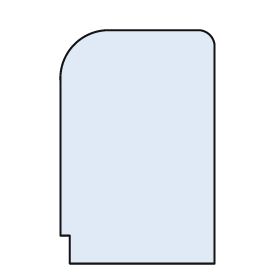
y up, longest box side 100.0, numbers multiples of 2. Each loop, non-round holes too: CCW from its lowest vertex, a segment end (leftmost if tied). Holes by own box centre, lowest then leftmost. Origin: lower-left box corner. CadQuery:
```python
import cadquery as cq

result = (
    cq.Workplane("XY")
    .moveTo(4.0, 0.0)
    .lineTo(66.0, 0.0)
    .lineTo(66.0, 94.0)
    .threePointArc((64.0, 98.0), (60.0, 100.0))
    .lineTo(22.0, 100.0)
    .threePointArc((6.0, 94.0), (0.0, 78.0))
    .lineTo(0.0, 12.0)
    .lineTo(4.0, 12.0)
    .close()
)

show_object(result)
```